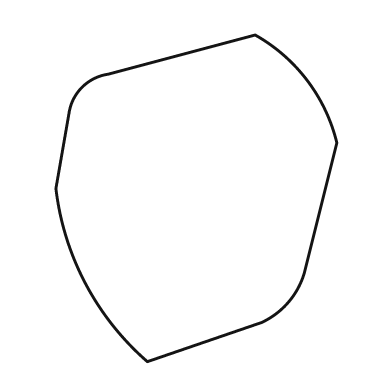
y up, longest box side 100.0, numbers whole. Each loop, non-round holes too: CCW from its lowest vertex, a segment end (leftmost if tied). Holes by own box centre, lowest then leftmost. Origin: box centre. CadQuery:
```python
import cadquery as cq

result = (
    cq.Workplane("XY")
    .moveTo(-15.0, -50.0)
    .lineTo(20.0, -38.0)
    .threePointArc((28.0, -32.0), (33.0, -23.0))
    .lineTo(43.0, 17.0)
    .threePointArc((34.0, 36.0), (18.0, 50.0))
    .lineTo(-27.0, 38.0)
    .threePointArc((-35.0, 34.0), (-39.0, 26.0))
    .lineTo(-43.0, 3.0)
    .threePointArc((-34.0, -26.0), (-15.0, -50.0))
    .close()
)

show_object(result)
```